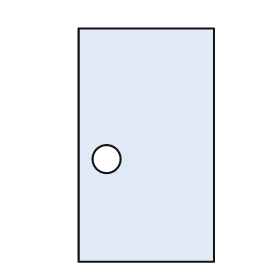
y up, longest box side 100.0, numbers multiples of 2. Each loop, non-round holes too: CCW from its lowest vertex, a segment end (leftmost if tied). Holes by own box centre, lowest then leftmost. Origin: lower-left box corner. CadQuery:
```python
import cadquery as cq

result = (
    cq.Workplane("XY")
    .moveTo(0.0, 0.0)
    .lineTo(58.0, 0.0)
    .lineTo(58.0, 100.0)
    .lineTo(0.0, 100.0)
    .close()
    .moveTo(12.0, 44.0)
    .circle(6.0)
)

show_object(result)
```